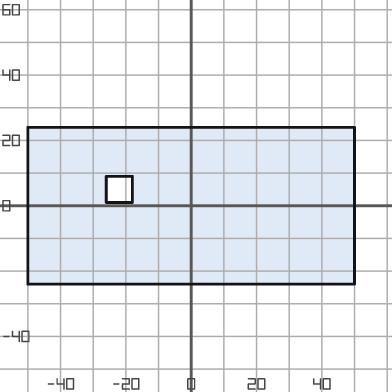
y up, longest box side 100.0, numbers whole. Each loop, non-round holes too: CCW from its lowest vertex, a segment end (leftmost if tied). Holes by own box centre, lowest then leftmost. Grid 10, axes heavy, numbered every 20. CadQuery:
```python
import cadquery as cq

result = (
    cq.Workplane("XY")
    .moveTo(-50.0, -24.0)
    .lineTo(50.0, -24.0)
    .lineTo(50.0, 24.0)
    .lineTo(-50.0, 24.0)
    .close()
    .moveTo(-26.0, 1.0)
    .lineTo(-18.0, 1.0)
    .lineTo(-18.0, 9.0)
    .lineTo(-26.0, 9.0)
    .close()
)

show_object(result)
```